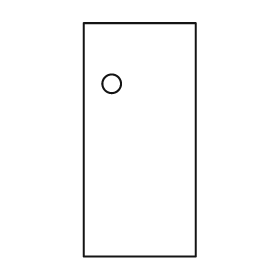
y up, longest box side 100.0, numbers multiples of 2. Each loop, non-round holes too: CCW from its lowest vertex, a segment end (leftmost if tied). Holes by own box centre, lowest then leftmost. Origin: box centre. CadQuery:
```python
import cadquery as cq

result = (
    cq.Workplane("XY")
    .moveTo(-24.0, -50.0)
    .lineTo(24.0, -50.0)
    .lineTo(24.0, 50.0)
    .lineTo(-24.0, 50.0)
    .close()
    .moveTo(-12.0, 24.0)
    .circle(4.0)
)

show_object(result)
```